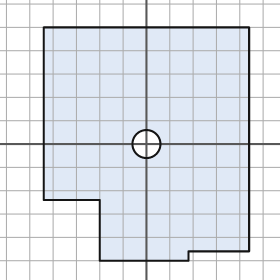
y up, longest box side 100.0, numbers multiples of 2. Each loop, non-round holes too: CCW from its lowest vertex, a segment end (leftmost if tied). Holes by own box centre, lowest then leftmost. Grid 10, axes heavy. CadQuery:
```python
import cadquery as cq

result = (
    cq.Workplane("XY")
    .moveTo(-20.0, -50.0)
    .lineTo(18.0, -50.0)
    .lineTo(18.0, -46.0)
    .lineTo(44.0, -46.0)
    .lineTo(44.0, 50.0)
    .lineTo(-44.0, 50.0)
    .lineTo(-44.0, -24.0)
    .lineTo(-20.0, -24.0)
    .close()
    .moveTo(0.0, 0.0)
    .circle(6.0)
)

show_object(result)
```